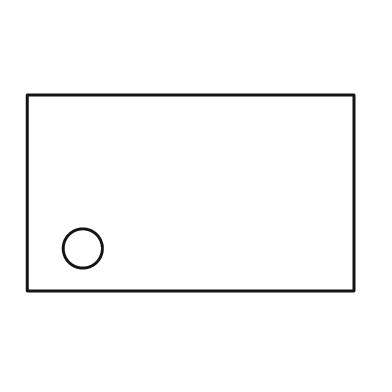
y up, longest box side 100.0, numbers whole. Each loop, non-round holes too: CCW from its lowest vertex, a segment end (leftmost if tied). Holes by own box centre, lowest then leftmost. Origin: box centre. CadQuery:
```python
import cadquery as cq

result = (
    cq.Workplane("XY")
    .moveTo(-50.0, -30.0)
    .lineTo(50.0, -30.0)
    .lineTo(50.0, 30.0)
    .lineTo(-50.0, 30.0)
    .close()
    .moveTo(-33.0, -17.0)
    .circle(6.0)
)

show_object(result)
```